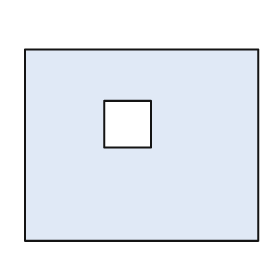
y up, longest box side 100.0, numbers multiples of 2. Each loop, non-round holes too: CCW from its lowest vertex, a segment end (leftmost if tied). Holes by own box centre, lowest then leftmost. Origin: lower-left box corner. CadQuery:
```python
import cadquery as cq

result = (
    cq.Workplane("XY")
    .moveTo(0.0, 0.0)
    .lineTo(100.0, 0.0)
    .lineTo(100.0, 82.0)
    .lineTo(0.0, 82.0)
    .close()
    .moveTo(34.0, 40.0)
    .lineTo(54.0, 40.0)
    .lineTo(54.0, 60.0)
    .lineTo(34.0, 60.0)
    .close()
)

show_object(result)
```